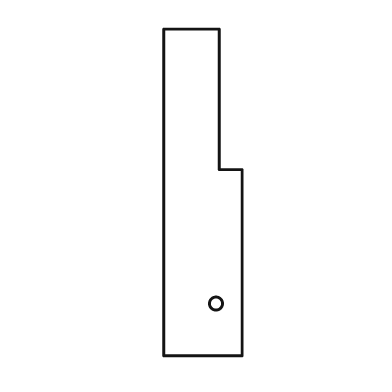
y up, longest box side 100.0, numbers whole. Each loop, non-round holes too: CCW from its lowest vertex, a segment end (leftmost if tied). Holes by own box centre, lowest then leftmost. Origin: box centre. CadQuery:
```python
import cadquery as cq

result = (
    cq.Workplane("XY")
    .moveTo(-12.0, -50.0)
    .lineTo(12.0, -50.0)
    .lineTo(12.0, 7.0)
    .lineTo(5.0, 7.0)
    .lineTo(5.0, 50.0)
    .lineTo(-12.0, 50.0)
    .close()
    .moveTo(4.0, -34.0)
    .circle(2.0)
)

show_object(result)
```